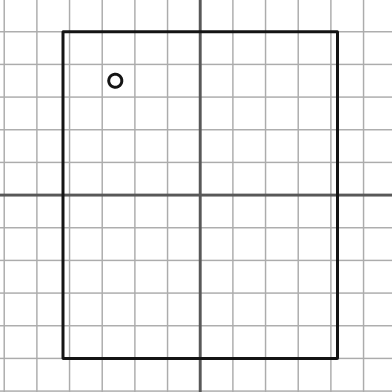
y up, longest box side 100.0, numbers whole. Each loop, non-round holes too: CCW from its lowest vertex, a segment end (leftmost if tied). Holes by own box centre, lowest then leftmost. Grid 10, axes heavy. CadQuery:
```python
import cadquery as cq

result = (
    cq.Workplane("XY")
    .moveTo(-42.0, -50.0)
    .lineTo(42.0, -50.0)
    .lineTo(42.0, 50.0)
    .lineTo(-42.0, 50.0)
    .close()
    .moveTo(-26.0, 35.0)
    .circle(2.0)
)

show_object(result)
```